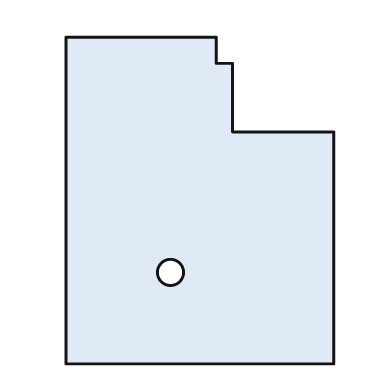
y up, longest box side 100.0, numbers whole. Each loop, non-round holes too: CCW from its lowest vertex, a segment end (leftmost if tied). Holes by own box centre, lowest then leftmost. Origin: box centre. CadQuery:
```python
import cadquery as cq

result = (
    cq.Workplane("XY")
    .moveTo(-41.0, -50.0)
    .lineTo(41.0, -50.0)
    .lineTo(41.0, 21.0)
    .lineTo(10.0, 21.0)
    .lineTo(10.0, 42.0)
    .lineTo(5.0, 42.0)
    .lineTo(5.0, 50.0)
    .lineTo(-41.0, 50.0)
    .close()
    .moveTo(-9.0, -22.0)
    .circle(4.0)
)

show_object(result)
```